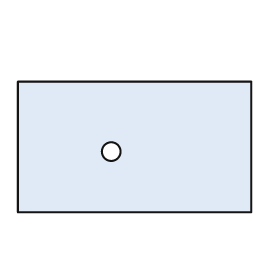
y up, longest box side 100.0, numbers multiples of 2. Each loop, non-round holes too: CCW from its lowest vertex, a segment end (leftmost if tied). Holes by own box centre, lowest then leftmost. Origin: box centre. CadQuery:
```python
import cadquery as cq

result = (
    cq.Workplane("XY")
    .moveTo(-50.0, -28.0)
    .lineTo(50.0, -28.0)
    .lineTo(50.0, 28.0)
    .lineTo(-50.0, 28.0)
    .close()
    .moveTo(-10.0, -2.0)
    .circle(4.0)
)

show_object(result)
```